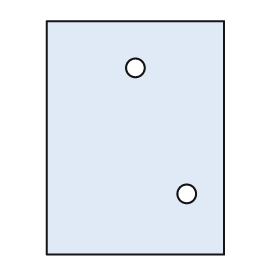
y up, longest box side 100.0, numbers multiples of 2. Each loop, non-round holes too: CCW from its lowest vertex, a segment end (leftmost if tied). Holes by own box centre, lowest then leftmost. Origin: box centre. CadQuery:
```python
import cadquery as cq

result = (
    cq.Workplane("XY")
    .moveTo(-38.0, -50.0)
    .lineTo(38.0, -50.0)
    .lineTo(38.0, 50.0)
    .lineTo(-38.0, 50.0)
    .close()
    .moveTo(22.0, -24.0)
    .circle(4.0)
    .moveTo(0.0, 30.0)
    .circle(4.0)
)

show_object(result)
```